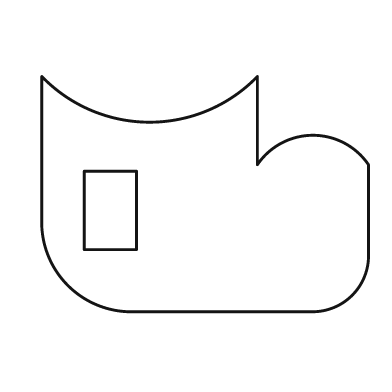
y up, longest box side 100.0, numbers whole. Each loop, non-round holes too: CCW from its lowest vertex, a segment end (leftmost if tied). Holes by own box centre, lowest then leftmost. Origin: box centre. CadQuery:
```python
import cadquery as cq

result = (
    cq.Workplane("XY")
    .moveTo(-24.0, -36.0)
    .lineTo(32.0, -36.0)
    .threePointArc((45.0, -31.0), (50.0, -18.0))
    .lineTo(50.0, 9.0)
    .threePointArc((33.0, 18.0), (16.0, 9.0))
    .lineTo(16.0, 36.0)
    .threePointArc((-17.0, 22.0), (-50.0, 36.0))
    .lineTo(-50.0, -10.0)
    .threePointArc((-42.0, -28.0), (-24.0, -36.0))
    .close()
    .moveTo(-37.0, -17.0)
    .lineTo(-21.0, -17.0)
    .lineTo(-21.0, 7.0)
    .lineTo(-37.0, 7.0)
    .close()
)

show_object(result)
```